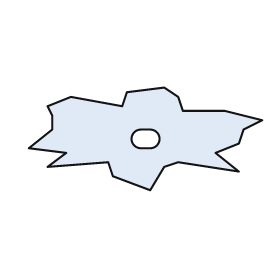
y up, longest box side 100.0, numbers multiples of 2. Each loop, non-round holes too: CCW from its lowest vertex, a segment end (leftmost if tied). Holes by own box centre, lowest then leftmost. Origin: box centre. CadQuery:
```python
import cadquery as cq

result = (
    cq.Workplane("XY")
    .moveTo(2.0, -22.0)
    .lineTo(8.0, -12.0)
    .lineTo(14.0, -10.0)
    .lineTo(40.0, -14.0)
    .lineTo(30.0, -6.0)
    .lineTo(40.0, -2.0)
    .lineTo(42.0, 4.0)
    .lineTo(50.0, 8.0)
    .lineTo(34.0, 12.0)
    .lineTo(16.0, 12.0)
    .lineTo(14.0, 18.0)
    .lineTo(8.0, 22.0)
    .lineTo(-8.0, 20.0)
    .lineTo(-10.0, 14.0)
    .lineTo(-32.0, 18.0)
    .lineTo(-42.0, 14.0)
    .lineTo(-40.0, 10.0)
    .lineTo(-40.0, 4.0)
    .lineTo(-50.0, -4.0)
    .lineTo(-34.0, -6.0)
    .lineTo(-42.0, -12.0)
    .lineTo(-16.0, -10.0)
    .lineTo(-14.0, -16.0)
    .close()
    .moveTo(-2.0, -4.0)
    .lineTo(2.0, -4.0)
    .threePointArc((6.0, 0.0), (2.0, 4.0))
    .lineTo(-2.0, 4.0)
    .threePointArc((-6.0, 0.0), (-2.0, -4.0))
    .close()
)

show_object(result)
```